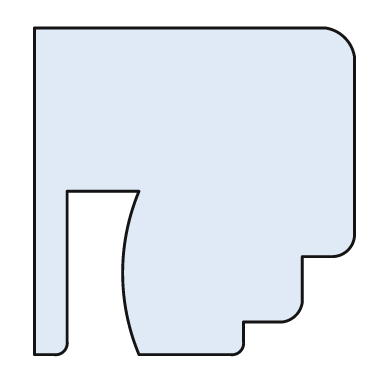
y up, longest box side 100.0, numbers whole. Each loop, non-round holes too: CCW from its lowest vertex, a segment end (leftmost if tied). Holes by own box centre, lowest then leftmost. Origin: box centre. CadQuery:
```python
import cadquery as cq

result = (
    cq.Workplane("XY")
    .moveTo(-49.0, -50.0)
    .lineTo(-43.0, -50.0)
    .threePointArc((-40.0, -49.0), (-39.0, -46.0))
    .lineTo(-39.0, 0.0)
    .lineTo(-17.0, 0.0)
    .threePointArc((-22.0, -25.0), (-17.0, -50.0))
    .lineTo(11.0, -50.0)
    .threePointArc((14.0, -49.0), (15.0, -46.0))
    .lineTo(15.0, -40.0)
    .lineTo(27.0, -40.0)
    .threePointArc((31.0, -38.0), (33.0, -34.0))
    .lineTo(33.0, -20.0)
    .lineTo(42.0, -20.0)
    .threePointArc((47.0, -18.0), (49.0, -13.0))
    .lineTo(49.0, 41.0)
    .threePointArc((46.0, 47.0), (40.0, 50.0))
    .lineTo(-49.0, 50.0)
    .close()
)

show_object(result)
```